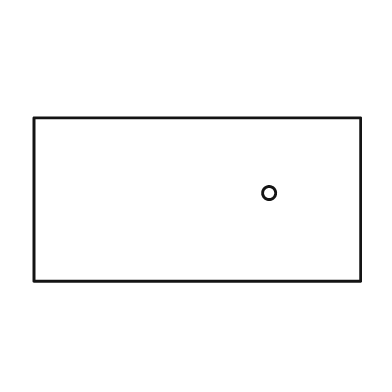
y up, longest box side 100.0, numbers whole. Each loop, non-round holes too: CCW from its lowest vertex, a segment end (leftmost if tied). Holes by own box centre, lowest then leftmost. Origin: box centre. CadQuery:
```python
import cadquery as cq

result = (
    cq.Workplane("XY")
    .moveTo(-50.0, -25.0)
    .lineTo(50.0, -25.0)
    .lineTo(50.0, 25.0)
    .lineTo(-50.0, 25.0)
    .close()
    .moveTo(22.0, 2.0)
    .circle(2.0)
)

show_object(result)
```